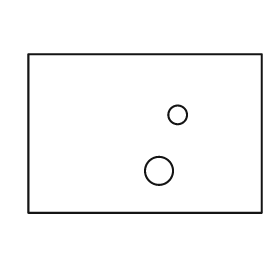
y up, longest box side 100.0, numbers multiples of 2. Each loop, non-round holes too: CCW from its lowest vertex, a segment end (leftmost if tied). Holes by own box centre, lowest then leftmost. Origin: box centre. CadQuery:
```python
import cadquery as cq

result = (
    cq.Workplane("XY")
    .moveTo(-50.0, -34.0)
    .lineTo(50.0, -34.0)
    .lineTo(50.0, 34.0)
    .lineTo(-50.0, 34.0)
    .close()
    .moveTo(6.0, -16.0)
    .circle(6.0)
    .moveTo(14.0, 8.0)
    .circle(4.0)
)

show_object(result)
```